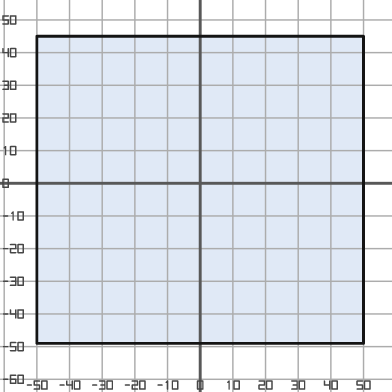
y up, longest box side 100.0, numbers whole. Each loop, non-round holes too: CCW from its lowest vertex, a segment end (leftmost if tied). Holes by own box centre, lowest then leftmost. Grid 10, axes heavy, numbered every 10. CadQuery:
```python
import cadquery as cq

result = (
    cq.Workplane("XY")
    .moveTo(-50.0, -49.0)
    .lineTo(50.0, -49.0)
    .lineTo(50.0, 45.0)
    .lineTo(-50.0, 45.0)
    .close()
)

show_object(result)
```